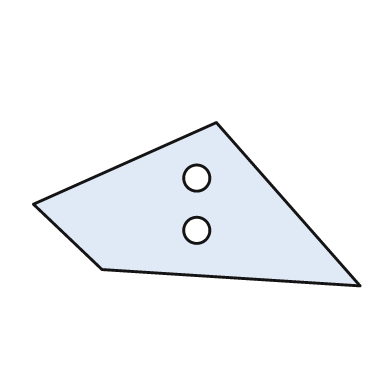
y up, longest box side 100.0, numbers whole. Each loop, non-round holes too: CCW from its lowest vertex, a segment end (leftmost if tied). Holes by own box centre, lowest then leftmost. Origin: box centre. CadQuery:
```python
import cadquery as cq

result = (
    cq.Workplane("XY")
    .moveTo(50.0, -25.0)
    .lineTo(6.0, 25.0)
    .lineTo(-50.0, 0.0)
    .lineTo(-29.0, -20.0)
    .close()
    .moveTo(0.0, -8.0)
    .circle(4.0)
    .moveTo(0.0, 8.0)
    .circle(4.0)
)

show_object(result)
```